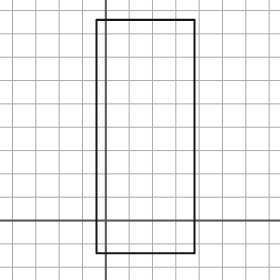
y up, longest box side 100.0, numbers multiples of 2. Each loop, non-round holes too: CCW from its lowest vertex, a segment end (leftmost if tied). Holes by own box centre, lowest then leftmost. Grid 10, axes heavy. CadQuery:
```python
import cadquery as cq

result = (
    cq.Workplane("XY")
    .moveTo(-4.0, -14.0)
    .lineTo(38.0, -14.0)
    .lineTo(38.0, 86.0)
    .lineTo(-4.0, 86.0)
    .close()
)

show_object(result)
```